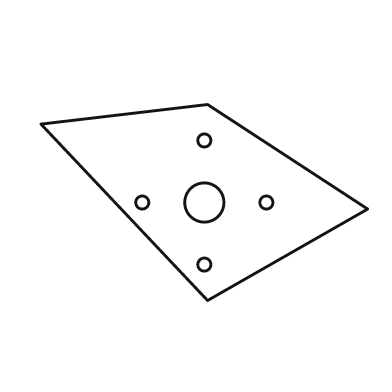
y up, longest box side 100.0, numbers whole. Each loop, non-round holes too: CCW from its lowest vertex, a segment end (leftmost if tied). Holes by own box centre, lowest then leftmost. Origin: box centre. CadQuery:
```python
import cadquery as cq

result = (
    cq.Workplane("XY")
    .moveTo(1.0, -30.0)
    .lineTo(50.0, -2.0)
    .lineTo(1.0, 30.0)
    .lineTo(-50.0, 24.0)
    .close()
    .moveTo(0.0, -19.0)
    .circle(2.0)
    .moveTo(-19.0, 0.0)
    .circle(2.0)
    .moveTo(0.0, 0.0)
    .circle(6.0)
    .moveTo(19.0, 0.0)
    .circle(2.0)
    .moveTo(0.0, 19.0)
    .circle(2.0)
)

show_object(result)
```